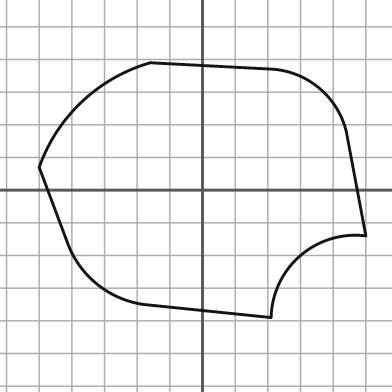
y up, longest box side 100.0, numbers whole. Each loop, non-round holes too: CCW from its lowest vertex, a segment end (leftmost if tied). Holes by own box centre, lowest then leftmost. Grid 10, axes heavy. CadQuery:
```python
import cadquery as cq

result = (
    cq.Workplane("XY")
    .moveTo(21.0, -39.0)
    .threePointArc((30.0, -20.0), (50.0, -14.0))
    .lineTo(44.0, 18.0)
    .threePointArc((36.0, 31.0), (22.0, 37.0))
    .lineTo(-16.0, 39.0)
    .threePointArc((-37.0, 27.0), (-50.0, 7.0))
    .lineTo(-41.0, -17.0)
    .threePointArc((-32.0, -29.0), (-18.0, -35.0))
    .close()
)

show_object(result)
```